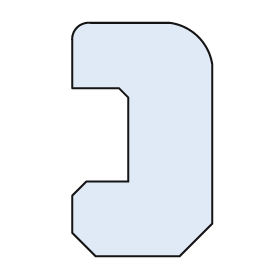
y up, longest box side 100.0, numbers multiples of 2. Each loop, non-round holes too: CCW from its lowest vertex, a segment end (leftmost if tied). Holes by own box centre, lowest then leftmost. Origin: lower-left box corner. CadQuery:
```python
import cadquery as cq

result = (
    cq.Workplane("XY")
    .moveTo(10.0, 0.0)
    .lineTo(46.0, 0.0)
    .lineTo(60.0, 14.0)
    .lineTo(60.0, 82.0)
    .threePointArc((54.0, 94.0), (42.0, 100.0))
    .lineTo(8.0, 100.0)
    .threePointArc((2.0, 98.0), (0.0, 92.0))
    .lineTo(0.0, 72.0)
    .lineTo(20.0, 72.0)
    .lineTo(24.0, 68.0)
    .lineTo(24.0, 32.0)
    .lineTo(6.0, 32.0)
    .lineTo(0.0, 26.0)
    .lineTo(0.0, 10.0)
    .close()
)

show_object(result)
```